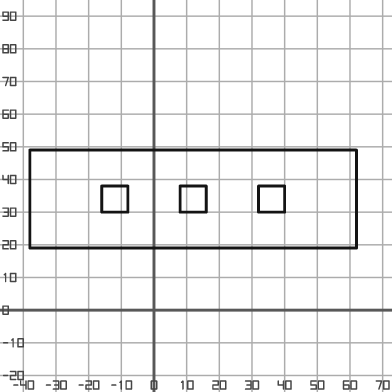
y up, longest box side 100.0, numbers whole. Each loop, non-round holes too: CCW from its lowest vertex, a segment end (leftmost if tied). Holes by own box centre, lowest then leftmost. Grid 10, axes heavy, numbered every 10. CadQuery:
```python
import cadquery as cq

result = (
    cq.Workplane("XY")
    .moveTo(-38.0, 19.0)
    .lineTo(62.0, 19.0)
    .lineTo(62.0, 49.0)
    .lineTo(-38.0, 49.0)
    .close()
    .moveTo(-16.0, 30.0)
    .lineTo(-8.0, 30.0)
    .lineTo(-8.0, 38.0)
    .lineTo(-16.0, 38.0)
    .close()
    .moveTo(8.0, 30.0)
    .lineTo(16.0, 30.0)
    .lineTo(16.0, 38.0)
    .lineTo(8.0, 38.0)
    .close()
    .moveTo(32.0, 30.0)
    .lineTo(40.0, 30.0)
    .lineTo(40.0, 38.0)
    .lineTo(32.0, 38.0)
    .close()
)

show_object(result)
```